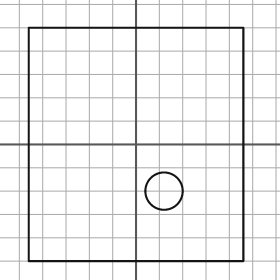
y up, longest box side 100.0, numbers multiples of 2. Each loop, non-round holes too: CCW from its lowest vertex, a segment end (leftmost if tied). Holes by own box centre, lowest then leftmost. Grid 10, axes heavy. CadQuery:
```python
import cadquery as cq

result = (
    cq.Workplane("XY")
    .moveTo(-46.0, -50.0)
    .lineTo(46.0, -50.0)
    .lineTo(46.0, 50.0)
    .lineTo(-46.0, 50.0)
    .close()
    .moveTo(12.0, -20.0)
    .circle(8.0)
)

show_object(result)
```